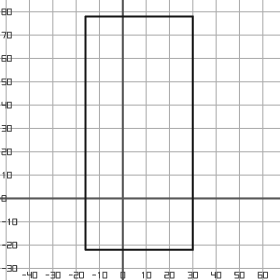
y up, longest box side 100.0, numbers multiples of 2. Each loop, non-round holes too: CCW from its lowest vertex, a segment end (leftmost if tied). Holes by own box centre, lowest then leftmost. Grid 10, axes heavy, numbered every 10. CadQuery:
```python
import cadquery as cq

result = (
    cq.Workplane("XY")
    .moveTo(-16.0, -22.0)
    .lineTo(30.0, -22.0)
    .lineTo(30.0, 78.0)
    .lineTo(-16.0, 78.0)
    .close()
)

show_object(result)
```